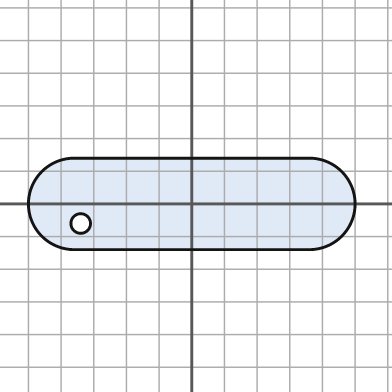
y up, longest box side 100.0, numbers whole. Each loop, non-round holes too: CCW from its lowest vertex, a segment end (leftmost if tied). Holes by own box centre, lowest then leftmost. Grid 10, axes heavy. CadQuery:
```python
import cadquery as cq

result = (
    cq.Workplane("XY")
    .moveTo(-36.0, -14.0)
    .lineTo(36.0, -14.0)
    .threePointArc((50.0, 0.0), (36.0, 14.0))
    .lineTo(-36.0, 14.0)
    .threePointArc((-50.0, 0.0), (-36.0, -14.0))
    .close()
    .moveTo(-34.0, -6.0)
    .circle(3.0)
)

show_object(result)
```